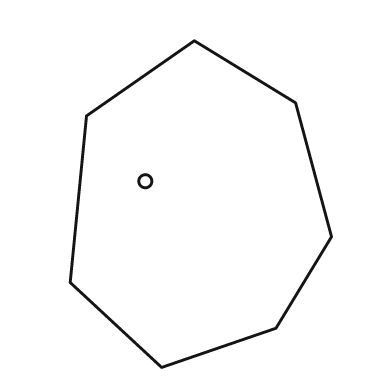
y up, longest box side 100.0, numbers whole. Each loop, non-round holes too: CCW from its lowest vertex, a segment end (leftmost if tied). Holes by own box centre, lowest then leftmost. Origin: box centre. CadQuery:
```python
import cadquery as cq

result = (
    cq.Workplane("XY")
    .moveTo(-12.0, -50.0)
    .lineTo(23.0, -38.0)
    .lineTo(40.0, -10.0)
    .lineTo(29.0, 31.0)
    .lineTo(-2.0, 50.0)
    .lineTo(-35.0, 27.0)
    .lineTo(-40.0, -24.0)
    .close()
    .moveTo(-17.0, 7.0)
    .circle(2.0)
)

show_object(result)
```